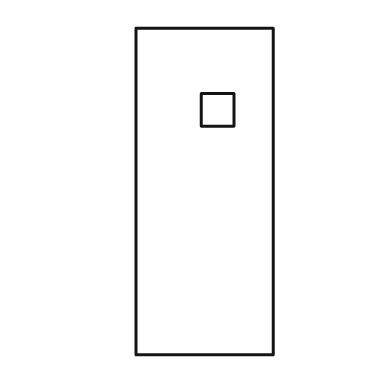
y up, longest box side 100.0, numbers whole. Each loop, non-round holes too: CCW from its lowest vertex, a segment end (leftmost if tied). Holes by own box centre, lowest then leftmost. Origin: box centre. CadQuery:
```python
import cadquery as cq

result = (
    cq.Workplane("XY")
    .moveTo(-21.0, -50.0)
    .lineTo(21.0, -50.0)
    .lineTo(21.0, 50.0)
    .lineTo(-21.0, 50.0)
    .close()
    .moveTo(-1.0, 20.0)
    .lineTo(9.0, 20.0)
    .lineTo(9.0, 30.0)
    .lineTo(-1.0, 30.0)
    .close()
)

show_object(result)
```